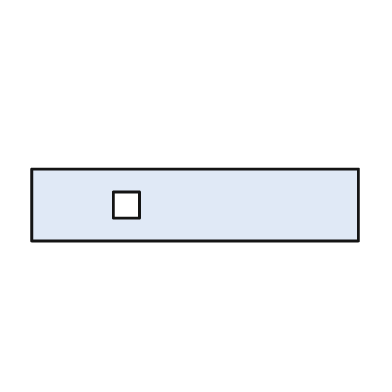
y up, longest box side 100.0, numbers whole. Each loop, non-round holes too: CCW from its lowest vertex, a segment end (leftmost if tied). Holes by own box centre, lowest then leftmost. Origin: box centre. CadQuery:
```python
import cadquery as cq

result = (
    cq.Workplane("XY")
    .moveTo(-50.0, -11.0)
    .lineTo(50.0, -11.0)
    .lineTo(50.0, 11.0)
    .lineTo(-50.0, 11.0)
    .close()
    .moveTo(-25.0, -4.0)
    .lineTo(-17.0, -4.0)
    .lineTo(-17.0, 4.0)
    .lineTo(-25.0, 4.0)
    .close()
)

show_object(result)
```